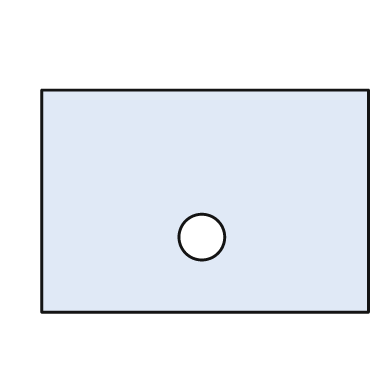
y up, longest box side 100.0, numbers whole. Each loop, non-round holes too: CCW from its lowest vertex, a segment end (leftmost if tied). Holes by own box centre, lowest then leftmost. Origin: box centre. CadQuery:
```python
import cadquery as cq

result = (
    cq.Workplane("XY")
    .moveTo(-50.0, -34.0)
    .lineTo(50.0, -34.0)
    .lineTo(50.0, 34.0)
    .lineTo(-50.0, 34.0)
    .close()
    .moveTo(-1.0, -11.0)
    .circle(7.0)
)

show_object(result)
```